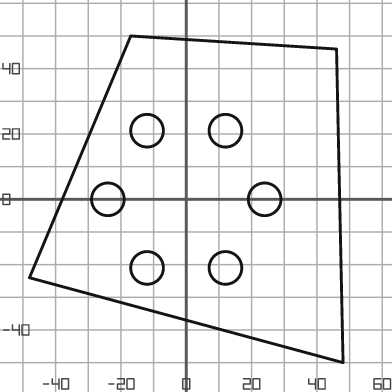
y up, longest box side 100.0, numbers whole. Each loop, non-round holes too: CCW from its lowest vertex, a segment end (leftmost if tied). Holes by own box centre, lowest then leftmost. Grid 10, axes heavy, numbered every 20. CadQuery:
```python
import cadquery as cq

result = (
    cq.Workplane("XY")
    .moveTo(48.0, -50.0)
    .lineTo(46.0, 46.0)
    .lineTo(-17.0, 50.0)
    .lineTo(-48.0, -24.0)
    .close()
    .moveTo(-12.0, -21.0)
    .circle(5.0)
    .moveTo(12.0, -21.0)
    .circle(5.0)
    .moveTo(-24.0, 0.0)
    .circle(5.0)
    .moveTo(24.0, 0.0)
    .circle(5.0)
    .moveTo(-12.0, 21.0)
    .circle(5.0)
    .moveTo(12.0, 21.0)
    .circle(5.0)
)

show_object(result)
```